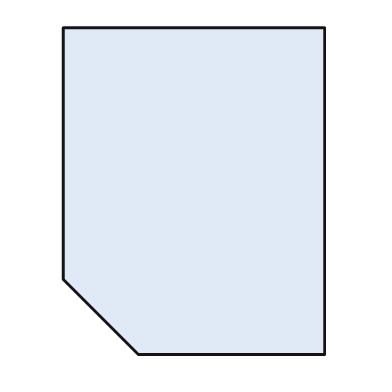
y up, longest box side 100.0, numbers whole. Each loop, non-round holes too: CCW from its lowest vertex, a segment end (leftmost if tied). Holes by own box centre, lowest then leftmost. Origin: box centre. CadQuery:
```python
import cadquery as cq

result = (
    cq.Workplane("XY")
    .moveTo(-17.0, -50.0)
    .lineTo(40.0, -50.0)
    .lineTo(40.0, 50.0)
    .lineTo(-40.0, 50.0)
    .lineTo(-40.0, -27.0)
    .close()
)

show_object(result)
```